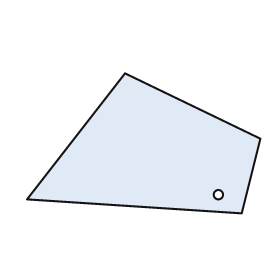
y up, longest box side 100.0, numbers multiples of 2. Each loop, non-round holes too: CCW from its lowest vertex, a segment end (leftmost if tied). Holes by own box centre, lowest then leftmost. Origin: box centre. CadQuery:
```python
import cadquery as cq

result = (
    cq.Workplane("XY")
    .moveTo(42.0, -30.0)
    .lineTo(50.0, 2.0)
    .lineTo(-8.0, 30.0)
    .lineTo(-50.0, -24.0)
    .close()
    .moveTo(32.0, -22.0)
    .circle(2.0)
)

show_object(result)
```